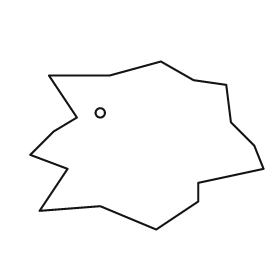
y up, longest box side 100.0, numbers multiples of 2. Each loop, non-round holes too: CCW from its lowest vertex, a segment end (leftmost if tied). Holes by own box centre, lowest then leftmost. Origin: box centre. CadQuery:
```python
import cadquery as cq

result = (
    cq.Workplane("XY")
    .moveTo(4.0, -36.0)
    .lineTo(22.0, -24.0)
    .lineTo(22.0, -16.0)
    .lineTo(50.0, -10.0)
    .lineTo(46.0, 0.0)
    .lineTo(36.0, 10.0)
    .lineTo(34.0, 26.0)
    .lineTo(20.0, 28.0)
    .lineTo(6.0, 36.0)
    .lineTo(-16.0, 30.0)
    .lineTo(-42.0, 30.0)
    .lineTo(-30.0, 12.0)
    .lineTo(-40.0, 6.0)
    .lineTo(-50.0, -4.0)
    .lineTo(-34.0, -10.0)
    .lineTo(-46.0, -28.0)
    .lineTo(-20.0, -26.0)
    .close()
    .moveTo(-20.0, 14.0)
    .circle(2.0)
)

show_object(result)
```